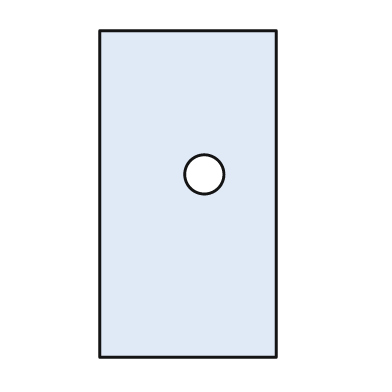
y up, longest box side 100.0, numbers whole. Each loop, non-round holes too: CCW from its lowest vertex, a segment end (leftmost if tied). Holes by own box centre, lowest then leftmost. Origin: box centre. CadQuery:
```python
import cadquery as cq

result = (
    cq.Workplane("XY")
    .moveTo(-27.0, -50.0)
    .lineTo(27.0, -50.0)
    .lineTo(27.0, 50.0)
    .lineTo(-27.0, 50.0)
    .close()
    .moveTo(5.0, 6.0)
    .circle(6.0)
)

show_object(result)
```